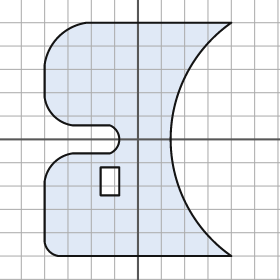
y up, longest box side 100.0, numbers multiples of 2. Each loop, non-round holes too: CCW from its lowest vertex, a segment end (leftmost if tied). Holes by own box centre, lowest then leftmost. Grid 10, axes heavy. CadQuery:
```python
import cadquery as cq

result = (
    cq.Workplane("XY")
    .moveTo(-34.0, -50.0)
    .lineTo(40.0, -50.0)
    .threePointArc((14.0, 0.0), (40.0, 50.0))
    .lineTo(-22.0, 50.0)
    .threePointArc((-34.0, 44.0), (-40.0, 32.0))
    .lineTo(-40.0, 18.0)
    .threePointArc((-36.0, 10.0), (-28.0, 6.0))
    .lineTo(-12.0, 6.0)
    .threePointArc((-8.0, 0.0), (-12.0, -6.0))
    .lineTo(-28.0, -6.0)
    .threePointArc((-36.0, -10.0), (-40.0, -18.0))
    .lineTo(-40.0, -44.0)
    .threePointArc((-38.0, -48.0), (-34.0, -50.0))
    .close()
    .moveTo(-16.0, -24.0)
    .lineTo(-8.0, -24.0)
    .lineTo(-8.0, -12.0)
    .lineTo(-16.0, -12.0)
    .close()
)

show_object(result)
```